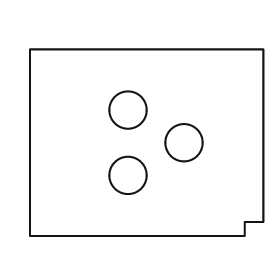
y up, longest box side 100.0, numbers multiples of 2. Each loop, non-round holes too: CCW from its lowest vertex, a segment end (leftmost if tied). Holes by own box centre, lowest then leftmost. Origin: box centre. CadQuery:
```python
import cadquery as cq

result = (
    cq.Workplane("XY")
    .moveTo(-50.0, -40.0)
    .lineTo(42.0, -40.0)
    .lineTo(42.0, -34.0)
    .lineTo(50.0, -34.0)
    .lineTo(50.0, 40.0)
    .lineTo(-50.0, 40.0)
    .close()
    .moveTo(-8.0, -14.0)
    .circle(8.0)
    .moveTo(16.0, 0.0)
    .circle(8.0)
    .moveTo(-8.0, 14.0)
    .circle(8.0)
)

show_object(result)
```